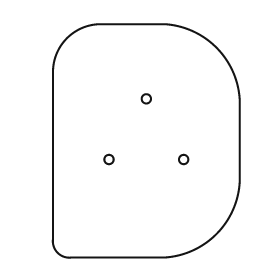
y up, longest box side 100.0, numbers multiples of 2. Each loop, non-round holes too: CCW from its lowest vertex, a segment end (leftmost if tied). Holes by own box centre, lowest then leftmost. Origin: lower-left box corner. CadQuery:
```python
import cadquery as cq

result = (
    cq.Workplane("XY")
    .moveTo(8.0, 0.0)
    .lineTo(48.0, 0.0)
    .threePointArc((70.0, 10.0), (80.0, 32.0))
    .lineTo(80.0, 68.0)
    .threePointArc((70.0, 90.0), (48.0, 100.0))
    .lineTo(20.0, 100.0)
    .threePointArc((6.0, 94.0), (0.0, 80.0))
    .lineTo(0.0, 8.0)
    .threePointArc((2.0, 2.0), (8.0, 0.0))
    .close()
    .moveTo(24.0, 42.0)
    .circle(2.0)
    .moveTo(56.0, 42.0)
    .circle(2.0)
    .moveTo(40.0, 68.0)
    .circle(2.0)
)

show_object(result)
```